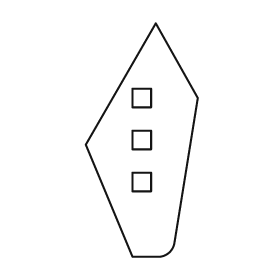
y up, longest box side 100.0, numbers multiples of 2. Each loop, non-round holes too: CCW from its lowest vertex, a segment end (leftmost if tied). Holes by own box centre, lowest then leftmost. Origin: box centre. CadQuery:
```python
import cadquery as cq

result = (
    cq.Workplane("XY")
    .moveTo(-4.0, -50.0)
    .lineTo(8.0, -50.0)
    .threePointArc((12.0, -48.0), (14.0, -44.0))
    .lineTo(24.0, 18.0)
    .lineTo(6.0, 50.0)
    .lineTo(-24.0, -2.0)
    .close()
    .moveTo(-4.0, -22.0)
    .lineTo(4.0, -22.0)
    .lineTo(4.0, -14.0)
    .lineTo(-4.0, -14.0)
    .close()
    .moveTo(-4.0, -4.0)
    .lineTo(4.0, -4.0)
    .lineTo(4.0, 4.0)
    .lineTo(-4.0, 4.0)
    .close()
    .moveTo(-4.0, 14.0)
    .lineTo(4.0, 14.0)
    .lineTo(4.0, 22.0)
    .lineTo(-4.0, 22.0)
    .close()
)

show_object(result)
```